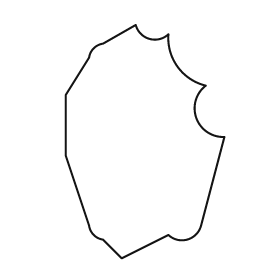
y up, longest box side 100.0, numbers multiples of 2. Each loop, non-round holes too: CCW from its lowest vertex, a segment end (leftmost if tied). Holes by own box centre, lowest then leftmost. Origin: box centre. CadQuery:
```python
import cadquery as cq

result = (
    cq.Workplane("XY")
    .moveTo(-10.0, -50.0)
    .lineTo(10.0, -40.0)
    .threePointArc((18.0, -42.0), (24.0, -36.0))
    .lineTo(34.0, 2.0)
    .threePointArc((22.0, 10.0), (26.0, 24.0))
    .threePointArc((14.0, 32.0), (10.0, 46.0))
    .threePointArc((2.0, 44.0), (-4.0, 50.0))
    .lineTo(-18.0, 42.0)
    .threePointArc((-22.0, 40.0), (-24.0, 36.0))
    .lineTo(-34.0, 20.0)
    .lineTo(-34.0, -6.0)
    .lineTo(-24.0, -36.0)
    .threePointArc((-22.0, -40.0), (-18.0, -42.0))
    .close()
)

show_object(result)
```